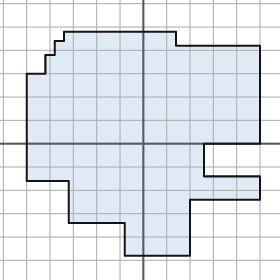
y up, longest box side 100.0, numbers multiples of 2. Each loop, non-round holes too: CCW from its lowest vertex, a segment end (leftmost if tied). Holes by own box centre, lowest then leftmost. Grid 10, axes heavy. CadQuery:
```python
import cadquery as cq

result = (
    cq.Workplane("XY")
    .moveTo(-8.0, -48.0)
    .lineTo(20.0, -48.0)
    .lineTo(20.0, -24.0)
    .lineTo(50.0, -24.0)
    .lineTo(50.0, -14.0)
    .lineTo(26.0, -14.0)
    .lineTo(26.0, 0.0)
    .lineTo(50.0, 0.0)
    .lineTo(50.0, 42.0)
    .lineTo(14.0, 42.0)
    .lineTo(14.0, 48.0)
    .lineTo(-34.0, 48.0)
    .lineTo(-34.0, 44.0)
    .lineTo(-38.0, 44.0)
    .lineTo(-38.0, 38.0)
    .lineTo(-42.0, 38.0)
    .lineTo(-42.0, 30.0)
    .lineTo(-50.0, 30.0)
    .lineTo(-50.0, -16.0)
    .lineTo(-32.0, -16.0)
    .lineTo(-32.0, -34.0)
    .lineTo(-8.0, -34.0)
    .close()
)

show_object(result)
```